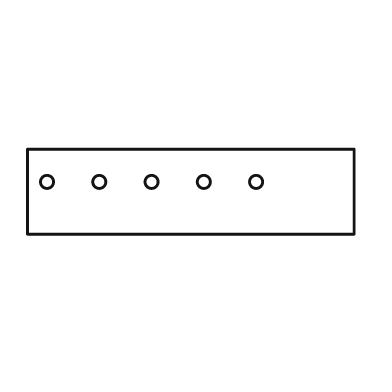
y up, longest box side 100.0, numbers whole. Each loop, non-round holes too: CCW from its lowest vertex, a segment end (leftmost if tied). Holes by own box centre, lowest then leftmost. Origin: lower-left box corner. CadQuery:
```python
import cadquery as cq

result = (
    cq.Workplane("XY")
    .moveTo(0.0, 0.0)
    .lineTo(100.0, 0.0)
    .lineTo(100.0, 26.0)
    .lineTo(0.0, 26.0)
    .close()
    .moveTo(6.0, 16.0)
    .circle(2.0)
    .moveTo(22.0, 16.0)
    .circle(2.0)
    .moveTo(38.0, 16.0)
    .circle(2.0)
    .moveTo(54.0, 16.0)
    .circle(2.0)
    .moveTo(70.0, 16.0)
    .circle(2.0)
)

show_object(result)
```